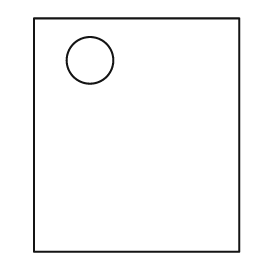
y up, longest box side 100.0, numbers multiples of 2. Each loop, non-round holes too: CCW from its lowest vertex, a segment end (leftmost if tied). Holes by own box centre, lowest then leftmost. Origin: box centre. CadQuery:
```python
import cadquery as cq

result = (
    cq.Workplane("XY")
    .moveTo(-44.0, -50.0)
    .lineTo(44.0, -50.0)
    .lineTo(44.0, 50.0)
    .lineTo(-44.0, 50.0)
    .close()
    .moveTo(-20.0, 32.0)
    .circle(10.0)
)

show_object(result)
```